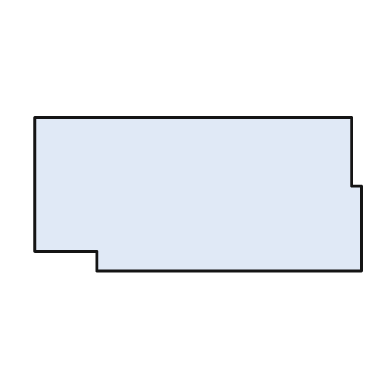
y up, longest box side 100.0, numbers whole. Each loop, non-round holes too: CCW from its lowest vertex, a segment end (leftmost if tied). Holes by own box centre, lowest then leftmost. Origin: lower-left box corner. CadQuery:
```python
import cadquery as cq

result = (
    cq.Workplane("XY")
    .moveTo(19.0, 0.0)
    .lineTo(100.0, 0.0)
    .lineTo(100.0, 26.0)
    .lineTo(97.0, 26.0)
    .lineTo(97.0, 47.0)
    .lineTo(0.0, 47.0)
    .lineTo(0.0, 6.0)
    .lineTo(19.0, 6.0)
    .close()
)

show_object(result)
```